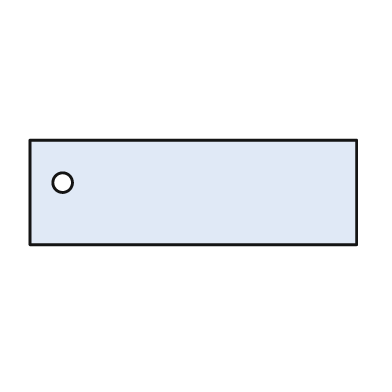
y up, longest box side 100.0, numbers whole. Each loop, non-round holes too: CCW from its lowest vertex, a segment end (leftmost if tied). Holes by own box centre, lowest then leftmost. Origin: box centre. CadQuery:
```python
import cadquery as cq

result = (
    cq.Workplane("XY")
    .moveTo(-50.0, -16.0)
    .lineTo(50.0, -16.0)
    .lineTo(50.0, 16.0)
    .lineTo(-50.0, 16.0)
    .close()
    .moveTo(-40.0, 3.0)
    .circle(3.0)
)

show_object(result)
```